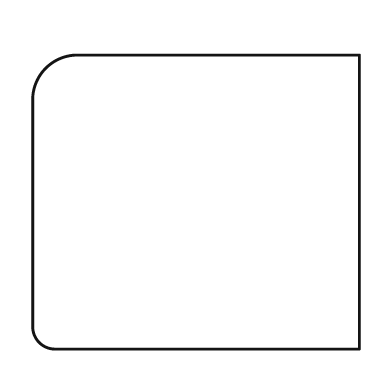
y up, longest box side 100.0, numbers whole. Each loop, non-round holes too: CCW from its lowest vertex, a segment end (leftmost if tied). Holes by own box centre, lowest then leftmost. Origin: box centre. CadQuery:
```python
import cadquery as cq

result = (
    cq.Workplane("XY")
    .moveTo(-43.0, -45.0)
    .lineTo(50.0, -45.0)
    .lineTo(50.0, 45.0)
    .lineTo(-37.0, 45.0)
    .threePointArc((-46.0, 41.0), (-50.0, 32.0))
    .lineTo(-50.0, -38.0)
    .threePointArc((-48.0, -43.0), (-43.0, -45.0))
    .close()
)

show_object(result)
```